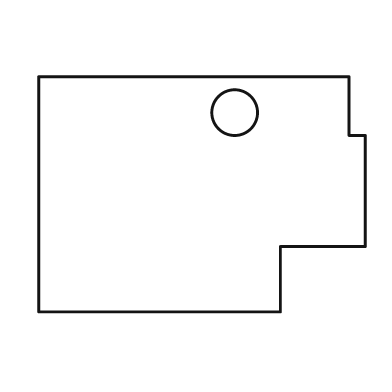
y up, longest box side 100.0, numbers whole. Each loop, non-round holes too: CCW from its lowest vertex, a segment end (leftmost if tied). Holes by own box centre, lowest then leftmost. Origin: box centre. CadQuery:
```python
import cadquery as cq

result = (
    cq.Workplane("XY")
    .moveTo(-50.0, -36.0)
    .lineTo(24.0, -36.0)
    .lineTo(24.0, -16.0)
    .lineTo(50.0, -16.0)
    .lineTo(50.0, 18.0)
    .lineTo(45.0, 18.0)
    .lineTo(45.0, 36.0)
    .lineTo(-50.0, 36.0)
    .close()
    .moveTo(10.0, 25.0)
    .circle(7.0)
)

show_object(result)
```